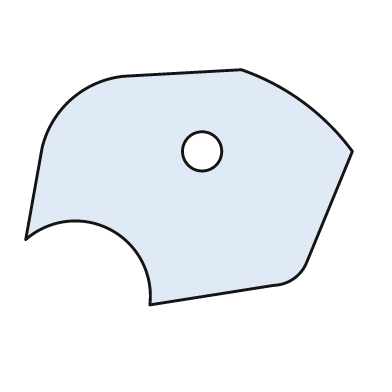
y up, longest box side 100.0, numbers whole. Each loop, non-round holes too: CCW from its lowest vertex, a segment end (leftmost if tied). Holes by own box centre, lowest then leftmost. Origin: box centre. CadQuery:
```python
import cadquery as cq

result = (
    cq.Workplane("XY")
    .moveTo(-12.0, -36.0)
    .lineTo(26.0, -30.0)
    .threePointArc((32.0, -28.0), (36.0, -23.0))
    .lineTo(50.0, 11.0)
    .threePointArc((35.0, 26.0), (16.0, 36.0))
    .lineTo(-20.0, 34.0)
    .threePointArc((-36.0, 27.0), (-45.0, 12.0))
    .lineTo(-50.0, -16.0)
    .threePointArc((-24.0, -13.0), (-12.0, -36.0))
    .close()
    .moveTo(4.0, 11.0)
    .circle(6.0)
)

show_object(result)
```